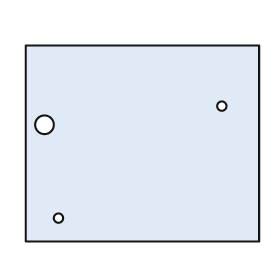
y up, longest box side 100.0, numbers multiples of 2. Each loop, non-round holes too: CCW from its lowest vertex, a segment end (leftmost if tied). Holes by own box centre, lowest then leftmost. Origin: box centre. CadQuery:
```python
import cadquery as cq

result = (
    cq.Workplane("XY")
    .moveTo(-50.0, -42.0)
    .lineTo(50.0, -42.0)
    .lineTo(50.0, 42.0)
    .lineTo(-50.0, 42.0)
    .close()
    .moveTo(-36.0, -32.0)
    .circle(2.0)
    .moveTo(-42.0, 8.0)
    .circle(4.0)
    .moveTo(34.0, 16.0)
    .circle(2.0)
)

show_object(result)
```